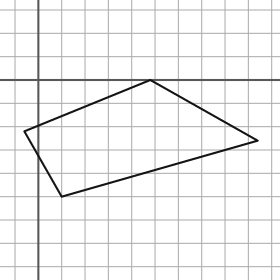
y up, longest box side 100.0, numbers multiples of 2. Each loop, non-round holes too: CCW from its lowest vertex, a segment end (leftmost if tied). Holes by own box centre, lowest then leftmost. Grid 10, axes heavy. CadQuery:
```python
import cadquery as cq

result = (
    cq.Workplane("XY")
    .moveTo(10.0, -50.0)
    .lineTo(94.0, -26.0)
    .lineTo(48.0, 0.0)
    .lineTo(-6.0, -22.0)
    .close()
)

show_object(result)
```